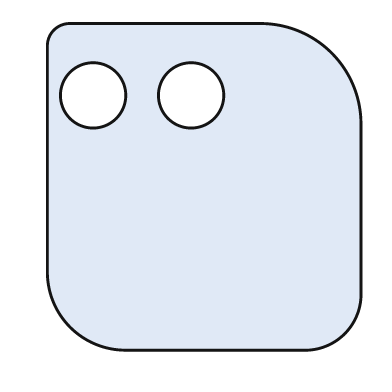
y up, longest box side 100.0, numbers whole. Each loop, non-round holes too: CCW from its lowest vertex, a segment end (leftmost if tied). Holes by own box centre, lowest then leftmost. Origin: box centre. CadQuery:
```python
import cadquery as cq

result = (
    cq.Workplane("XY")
    .moveTo(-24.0, -50.0)
    .lineTo(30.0, -50.0)
    .threePointArc((43.0, -45.0), (48.0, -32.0))
    .lineTo(48.0, 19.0)
    .threePointArc((39.0, 41.0), (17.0, 50.0))
    .lineTo(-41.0, 50.0)
    .threePointArc((-46.0, 48.0), (-48.0, 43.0))
    .lineTo(-48.0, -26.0)
    .threePointArc((-41.0, -43.0), (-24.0, -50.0))
    .close()
    .moveTo(-34.0, 28.0)
    .circle(10.0)
    .moveTo(-4.0, 28.0)
    .circle(10.0)
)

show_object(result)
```